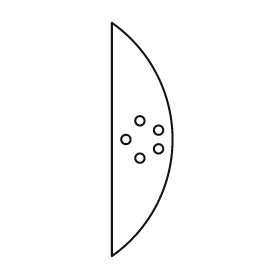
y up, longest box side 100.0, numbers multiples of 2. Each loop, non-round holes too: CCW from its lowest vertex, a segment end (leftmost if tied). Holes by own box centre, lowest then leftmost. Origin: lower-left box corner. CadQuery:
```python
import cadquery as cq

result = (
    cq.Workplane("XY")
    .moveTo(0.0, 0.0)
    .threePointArc((26.0, 50.0), (0.0, 100.0))
    .close()
    .moveTo(12.0, 42.0)
    .circle(2.0)
    .moveTo(20.0, 46.0)
    .circle(2.0)
    .moveTo(6.0, 50.0)
    .circle(2.0)
    .moveTo(20.0, 54.0)
    .circle(2.0)
    .moveTo(12.0, 58.0)
    .circle(2.0)
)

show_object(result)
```